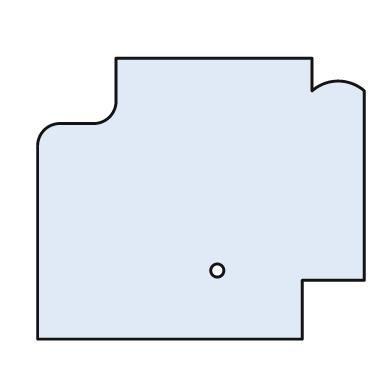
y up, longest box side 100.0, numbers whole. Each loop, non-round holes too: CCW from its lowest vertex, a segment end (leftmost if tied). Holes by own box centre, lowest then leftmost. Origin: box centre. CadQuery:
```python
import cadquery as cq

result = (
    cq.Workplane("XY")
    .moveTo(-50.0, -43.0)
    .lineTo(31.0, -43.0)
    .lineTo(31.0, -25.0)
    .lineTo(50.0, -25.0)
    .lineTo(50.0, 33.0)
    .threePointArc((42.0, 36.0), (34.0, 33.0))
    .lineTo(34.0, 43.0)
    .lineTo(-26.0, 43.0)
    .lineTo(-26.0, 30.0)
    .threePointArc((-28.0, 25.0), (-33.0, 23.0))
    .lineTo(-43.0, 23.0)
    .threePointArc((-48.0, 21.0), (-50.0, 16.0))
    .close()
    .moveTo(5.0, -22.0)
    .circle(2.0)
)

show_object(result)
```